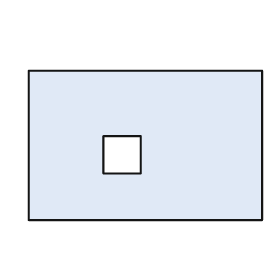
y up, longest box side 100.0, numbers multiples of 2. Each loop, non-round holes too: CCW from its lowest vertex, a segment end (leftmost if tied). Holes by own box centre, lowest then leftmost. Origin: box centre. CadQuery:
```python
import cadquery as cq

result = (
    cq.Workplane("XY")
    .moveTo(-50.0, -32.0)
    .lineTo(50.0, -32.0)
    .lineTo(50.0, 32.0)
    .lineTo(-50.0, 32.0)
    .close()
    .moveTo(-18.0, -12.0)
    .lineTo(-2.0, -12.0)
    .lineTo(-2.0, 4.0)
    .lineTo(-18.0, 4.0)
    .close()
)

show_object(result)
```